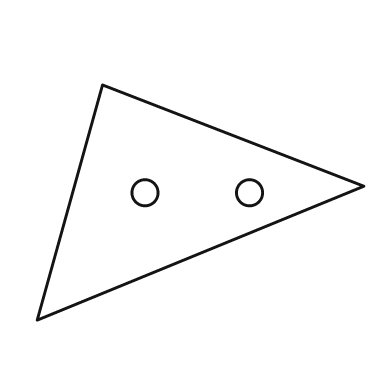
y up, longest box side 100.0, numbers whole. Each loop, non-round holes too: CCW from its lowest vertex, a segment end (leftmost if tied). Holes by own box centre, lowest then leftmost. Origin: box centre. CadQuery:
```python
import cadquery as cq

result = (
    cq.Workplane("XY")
    .moveTo(-50.0, -36.0)
    .lineTo(50.0, 5.0)
    .lineTo(-30.0, 36.0)
    .close()
    .moveTo(-17.0, 3.0)
    .circle(4.0)
    .moveTo(15.0, 3.0)
    .circle(4.0)
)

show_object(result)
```